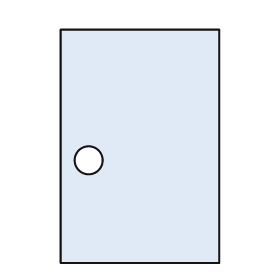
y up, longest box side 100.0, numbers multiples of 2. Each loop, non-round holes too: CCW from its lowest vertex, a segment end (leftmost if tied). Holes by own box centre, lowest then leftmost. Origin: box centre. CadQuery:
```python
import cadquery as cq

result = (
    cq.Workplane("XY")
    .moveTo(-34.0, -50.0)
    .lineTo(34.0, -50.0)
    .lineTo(34.0, 50.0)
    .lineTo(-34.0, 50.0)
    .close()
    .moveTo(-22.0, -6.0)
    .circle(6.0)
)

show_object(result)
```